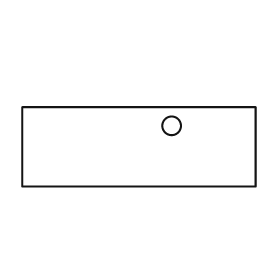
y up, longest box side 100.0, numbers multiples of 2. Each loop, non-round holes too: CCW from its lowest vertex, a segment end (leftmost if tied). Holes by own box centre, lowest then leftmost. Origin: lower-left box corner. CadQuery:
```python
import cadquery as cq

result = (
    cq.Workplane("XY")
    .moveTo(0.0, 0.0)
    .lineTo(100.0, 0.0)
    .lineTo(100.0, 34.0)
    .lineTo(0.0, 34.0)
    .close()
    .moveTo(64.0, 26.0)
    .circle(4.0)
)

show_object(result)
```